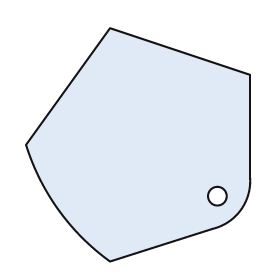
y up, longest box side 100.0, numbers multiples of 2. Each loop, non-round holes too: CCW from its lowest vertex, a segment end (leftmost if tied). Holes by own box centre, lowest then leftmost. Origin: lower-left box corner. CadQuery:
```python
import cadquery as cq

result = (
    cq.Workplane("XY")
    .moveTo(36.0, 0.0)
    .lineTo(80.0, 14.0)
    .threePointArc((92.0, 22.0), (96.0, 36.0))
    .lineTo(96.0, 80.0)
    .lineTo(36.0, 100.0)
    .lineTo(0.0, 50.0)
    .threePointArc((14.0, 22.0), (36.0, 0.0))
    .close()
    .moveTo(82.0, 28.0)
    .circle(4.0)
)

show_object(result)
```